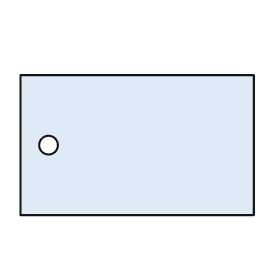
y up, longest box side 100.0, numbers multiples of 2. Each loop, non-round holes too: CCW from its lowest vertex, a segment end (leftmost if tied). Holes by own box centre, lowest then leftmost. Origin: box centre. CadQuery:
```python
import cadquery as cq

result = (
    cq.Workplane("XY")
    .moveTo(-50.0, -30.0)
    .lineTo(50.0, -30.0)
    .lineTo(50.0, 30.0)
    .lineTo(-50.0, 30.0)
    .close()
    .moveTo(-38.0, 0.0)
    .circle(4.0)
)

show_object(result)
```